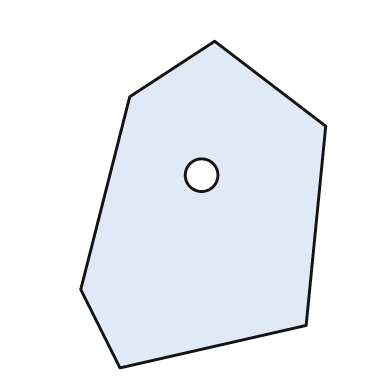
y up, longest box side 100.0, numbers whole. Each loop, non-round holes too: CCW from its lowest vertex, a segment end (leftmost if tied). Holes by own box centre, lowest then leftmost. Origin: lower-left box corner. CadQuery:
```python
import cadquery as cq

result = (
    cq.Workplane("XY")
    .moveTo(12.0, 0.0)
    .lineTo(69.0, 13.0)
    .lineTo(75.0, 74.0)
    .lineTo(41.0, 100.0)
    .lineTo(15.0, 83.0)
    .lineTo(0.0, 24.0)
    .close()
    .moveTo(37.0, 59.0)
    .circle(5.0)
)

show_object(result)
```